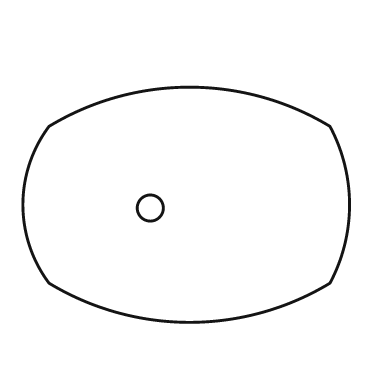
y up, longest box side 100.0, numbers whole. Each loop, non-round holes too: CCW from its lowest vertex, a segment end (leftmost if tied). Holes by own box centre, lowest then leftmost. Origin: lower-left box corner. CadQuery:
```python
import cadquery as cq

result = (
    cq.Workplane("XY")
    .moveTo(8.0, 12.0)
    .threePointArc((51.0, 0.0), (94.0, 12.0))
    .threePointArc((100.0, 36.0), (94.0, 60.0))
    .threePointArc((51.0, 72.0), (8.0, 60.0))
    .threePointArc((0.0, 36.0), (8.0, 12.0))
    .close()
    .moveTo(39.0, 35.0)
    .circle(4.0)
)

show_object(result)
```